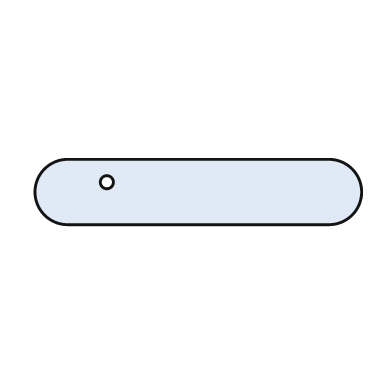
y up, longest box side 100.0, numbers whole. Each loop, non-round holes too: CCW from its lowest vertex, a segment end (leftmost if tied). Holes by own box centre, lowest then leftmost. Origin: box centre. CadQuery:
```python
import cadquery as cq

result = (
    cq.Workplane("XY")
    .moveTo(-40.0, -10.0)
    .lineTo(40.0, -10.0)
    .threePointArc((50.0, 0.0), (40.0, 10.0))
    .lineTo(-40.0, 10.0)
    .threePointArc((-50.0, 0.0), (-40.0, -10.0))
    .close()
    .moveTo(-28.0, 3.0)
    .circle(2.0)
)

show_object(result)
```